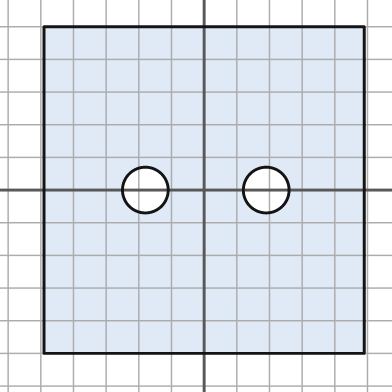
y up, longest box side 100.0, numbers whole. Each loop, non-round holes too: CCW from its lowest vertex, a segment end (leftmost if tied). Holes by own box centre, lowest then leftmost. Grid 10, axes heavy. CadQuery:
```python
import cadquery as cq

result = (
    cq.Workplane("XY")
    .moveTo(-49.0, -50.0)
    .lineTo(49.0, -50.0)
    .lineTo(49.0, 50.0)
    .lineTo(-49.0, 50.0)
    .close()
    .moveTo(-18.0, 0.0)
    .circle(7.0)
    .moveTo(19.0, 0.0)
    .circle(7.0)
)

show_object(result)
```